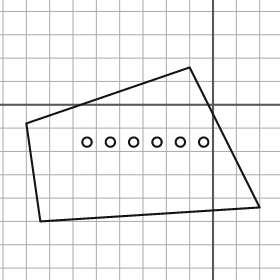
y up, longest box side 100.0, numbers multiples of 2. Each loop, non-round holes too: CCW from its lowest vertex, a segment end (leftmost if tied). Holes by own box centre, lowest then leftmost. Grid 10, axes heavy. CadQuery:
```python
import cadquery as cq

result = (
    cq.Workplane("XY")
    .moveTo(-74.0, -50.0)
    .lineTo(20.0, -44.0)
    .lineTo(-10.0, 16.0)
    .lineTo(-80.0, -8.0)
    .close()
    .moveTo(-54.0, -16.0)
    .circle(2.0)
    .moveTo(-44.0, -16.0)
    .circle(2.0)
    .moveTo(-34.0, -16.0)
    .circle(2.0)
    .moveTo(-24.0, -16.0)
    .circle(2.0)
    .moveTo(-14.0, -16.0)
    .circle(2.0)
    .moveTo(-4.0, -16.0)
    .circle(2.0)
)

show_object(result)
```